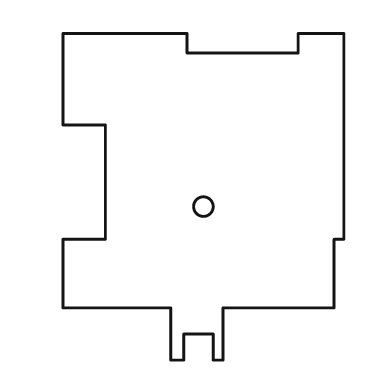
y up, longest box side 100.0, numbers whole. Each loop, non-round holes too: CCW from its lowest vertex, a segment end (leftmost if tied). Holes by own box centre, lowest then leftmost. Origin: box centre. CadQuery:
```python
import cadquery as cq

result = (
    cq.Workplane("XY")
    .moveTo(-10.0, -50.0)
    .lineTo(-6.0, -50.0)
    .lineTo(-6.0, -42.0)
    .lineTo(3.0, -42.0)
    .lineTo(3.0, -50.0)
    .lineTo(6.0, -50.0)
    .lineTo(6.0, -34.0)
    .lineTo(40.0, -34.0)
    .lineTo(40.0, -13.0)
    .lineTo(43.0, -13.0)
    .lineTo(43.0, 50.0)
    .lineTo(29.0, 50.0)
    .lineTo(29.0, 44.0)
    .lineTo(-5.0, 44.0)
    .lineTo(-5.0, 50.0)
    .lineTo(-43.0, 50.0)
    .lineTo(-43.0, 22.0)
    .lineTo(-30.0, 22.0)
    .lineTo(-30.0, -13.0)
    .lineTo(-43.0, -13.0)
    .lineTo(-43.0, -34.0)
    .lineTo(-10.0, -34.0)
    .close()
    .moveTo(0.0, -3.0)
    .circle(3.0)
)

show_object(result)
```